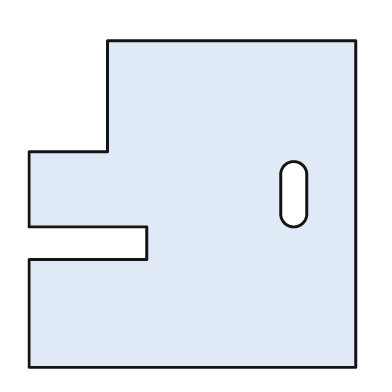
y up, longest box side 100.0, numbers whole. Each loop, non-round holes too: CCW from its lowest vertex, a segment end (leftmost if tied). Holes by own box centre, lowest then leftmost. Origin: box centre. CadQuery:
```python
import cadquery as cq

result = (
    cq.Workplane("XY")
    .moveTo(-50.0, -50.0)
    .lineTo(50.0, -50.0)
    .lineTo(50.0, 50.0)
    .lineTo(-26.0, 50.0)
    .lineTo(-26.0, 16.0)
    .lineTo(-50.0, 16.0)
    .lineTo(-50.0, -7.0)
    .lineTo(-14.0, -7.0)
    .lineTo(-14.0, -17.0)
    .lineTo(-50.0, -17.0)
    .close()
    .moveTo(27.0, -3.0)
    .threePointArc((31.0, -7.0), (35.0, -3.0))
    .lineTo(35.0, 9.0)
    .threePointArc((31.0, 13.0), (27.0, 9.0))
    .close()
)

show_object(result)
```